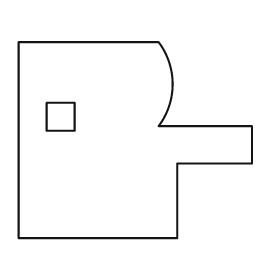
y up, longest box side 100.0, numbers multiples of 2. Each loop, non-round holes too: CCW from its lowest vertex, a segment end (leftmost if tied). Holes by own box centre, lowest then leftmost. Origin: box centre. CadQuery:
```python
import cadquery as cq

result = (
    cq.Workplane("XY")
    .moveTo(-50.0, -42.0)
    .lineTo(18.0, -42.0)
    .lineTo(18.0, -10.0)
    .lineTo(50.0, -10.0)
    .lineTo(50.0, 6.0)
    .lineTo(10.0, 6.0)
    .threePointArc((16.0, 24.0), (10.0, 42.0))
    .lineTo(-50.0, 42.0)
    .close()
    .moveTo(-38.0, 4.0)
    .lineTo(-26.0, 4.0)
    .lineTo(-26.0, 16.0)
    .lineTo(-38.0, 16.0)
    .close()
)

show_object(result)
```